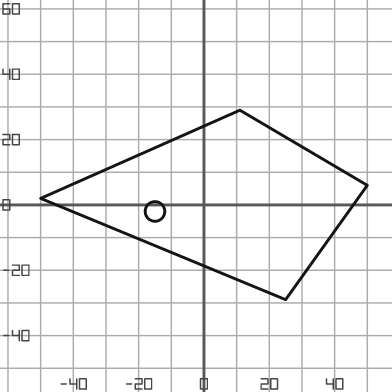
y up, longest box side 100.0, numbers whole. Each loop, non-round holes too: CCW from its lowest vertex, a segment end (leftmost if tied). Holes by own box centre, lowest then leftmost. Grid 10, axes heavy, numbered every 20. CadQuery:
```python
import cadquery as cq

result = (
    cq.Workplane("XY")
    .moveTo(25.0, -29.0)
    .lineTo(50.0, 6.0)
    .lineTo(11.0, 29.0)
    .lineTo(-50.0, 2.0)
    .close()
    .moveTo(-15.0, -2.0)
    .circle(3.0)
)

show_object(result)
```